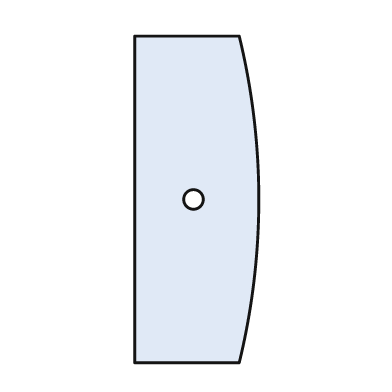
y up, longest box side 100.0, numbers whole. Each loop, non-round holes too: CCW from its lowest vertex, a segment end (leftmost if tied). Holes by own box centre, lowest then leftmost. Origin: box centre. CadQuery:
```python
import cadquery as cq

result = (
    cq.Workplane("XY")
    .moveTo(-19.0, -50.0)
    .lineTo(13.0, -50.0)
    .threePointArc((19.0, 0.0), (13.0, 50.0))
    .lineTo(-19.0, 50.0)
    .close()
    .moveTo(-1.0, 0.0)
    .circle(3.0)
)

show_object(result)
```